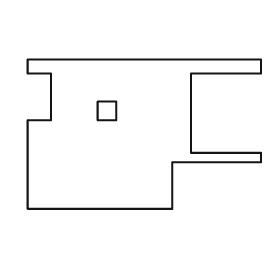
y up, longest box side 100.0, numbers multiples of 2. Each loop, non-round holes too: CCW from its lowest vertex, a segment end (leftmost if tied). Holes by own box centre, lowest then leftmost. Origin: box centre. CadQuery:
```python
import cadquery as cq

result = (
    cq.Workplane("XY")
    .moveTo(-50.0, -32.0)
    .lineTo(12.0, -32.0)
    .lineTo(12.0, -12.0)
    .lineTo(50.0, -12.0)
    .lineTo(50.0, -8.0)
    .lineTo(20.0, -8.0)
    .lineTo(20.0, 26.0)
    .lineTo(50.0, 26.0)
    .lineTo(50.0, 32.0)
    .lineTo(-50.0, 32.0)
    .lineTo(-50.0, 26.0)
    .lineTo(-40.0, 26.0)
    .lineTo(-40.0, 6.0)
    .lineTo(-50.0, 6.0)
    .close()
    .moveTo(-20.0, 6.0)
    .lineTo(-12.0, 6.0)
    .lineTo(-12.0, 14.0)
    .lineTo(-20.0, 14.0)
    .close()
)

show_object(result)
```